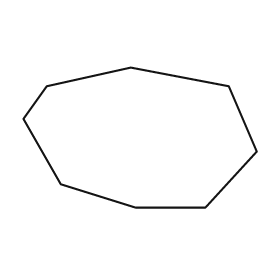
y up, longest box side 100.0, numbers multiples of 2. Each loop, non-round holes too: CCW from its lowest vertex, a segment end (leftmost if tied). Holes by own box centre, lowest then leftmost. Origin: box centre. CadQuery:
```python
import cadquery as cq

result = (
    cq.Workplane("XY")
    .moveTo(-2.0, -30.0)
    .lineTo(28.0, -30.0)
    .lineTo(50.0, -6.0)
    .lineTo(38.0, 22.0)
    .lineTo(-4.0, 30.0)
    .lineTo(-40.0, 22.0)
    .lineTo(-50.0, 8.0)
    .lineTo(-34.0, -20.0)
    .close()
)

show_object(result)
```